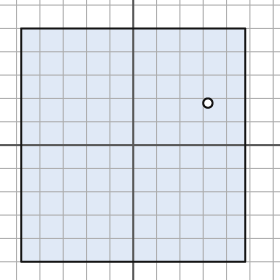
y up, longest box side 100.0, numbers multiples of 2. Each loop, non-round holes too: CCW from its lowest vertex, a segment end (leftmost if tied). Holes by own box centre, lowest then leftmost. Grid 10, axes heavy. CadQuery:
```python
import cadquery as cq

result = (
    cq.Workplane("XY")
    .moveTo(-48.0, -50.0)
    .lineTo(48.0, -50.0)
    .lineTo(48.0, 50.0)
    .lineTo(-48.0, 50.0)
    .close()
    .moveTo(32.0, 18.0)
    .circle(2.0)
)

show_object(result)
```